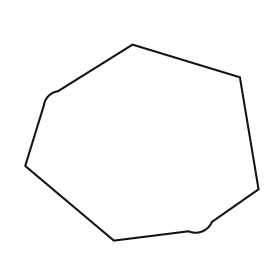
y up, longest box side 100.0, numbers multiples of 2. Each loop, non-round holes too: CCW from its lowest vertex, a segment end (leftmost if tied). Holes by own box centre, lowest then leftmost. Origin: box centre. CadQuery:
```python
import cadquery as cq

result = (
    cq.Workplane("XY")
    .moveTo(-12.0, -42.0)
    .lineTo(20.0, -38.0)
    .threePointArc((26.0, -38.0), (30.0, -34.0))
    .lineTo(50.0, -20.0)
    .lineTo(42.0, 28.0)
    .lineTo(-4.0, 42.0)
    .lineTo(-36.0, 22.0)
    .threePointArc((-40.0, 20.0), (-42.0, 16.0))
    .lineTo(-50.0, -10.0)
    .close()
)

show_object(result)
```